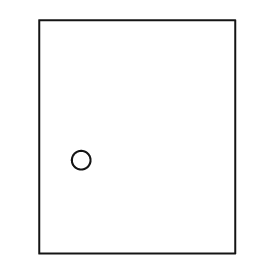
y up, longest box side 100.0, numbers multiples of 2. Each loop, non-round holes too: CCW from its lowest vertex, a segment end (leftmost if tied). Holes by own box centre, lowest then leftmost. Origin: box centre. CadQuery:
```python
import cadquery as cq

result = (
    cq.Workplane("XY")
    .moveTo(-42.0, -50.0)
    .lineTo(42.0, -50.0)
    .lineTo(42.0, 50.0)
    .lineTo(-42.0, 50.0)
    .close()
    .moveTo(-24.0, -10.0)
    .circle(4.0)
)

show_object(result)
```